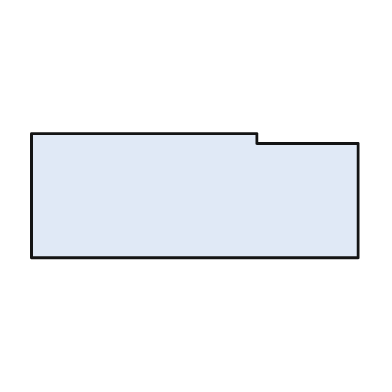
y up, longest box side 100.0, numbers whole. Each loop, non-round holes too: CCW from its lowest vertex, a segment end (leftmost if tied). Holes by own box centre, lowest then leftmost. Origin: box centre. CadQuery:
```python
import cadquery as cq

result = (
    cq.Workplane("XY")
    .moveTo(-50.0, -19.0)
    .lineTo(50.0, -19.0)
    .lineTo(50.0, 16.0)
    .lineTo(19.0, 16.0)
    .lineTo(19.0, 19.0)
    .lineTo(-50.0, 19.0)
    .close()
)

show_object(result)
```